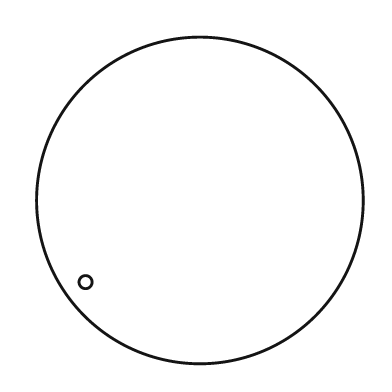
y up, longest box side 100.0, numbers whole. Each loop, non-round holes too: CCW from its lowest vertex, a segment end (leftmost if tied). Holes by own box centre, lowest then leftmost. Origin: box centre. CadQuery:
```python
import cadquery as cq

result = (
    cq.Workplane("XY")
    .moveTo(0.0, 0.0)
    .circle(50.0)
    .moveTo(-35.0, -25.0)
    .circle(2.0)
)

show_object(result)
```